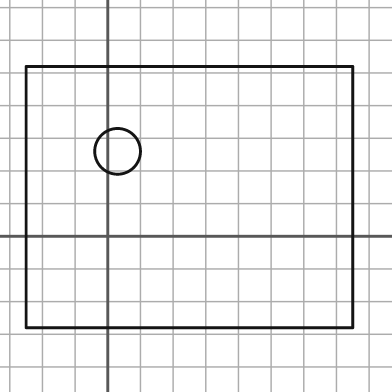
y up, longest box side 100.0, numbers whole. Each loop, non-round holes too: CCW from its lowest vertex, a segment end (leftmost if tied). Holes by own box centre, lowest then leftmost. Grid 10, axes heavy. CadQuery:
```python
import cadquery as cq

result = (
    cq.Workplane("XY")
    .moveTo(-25.0, -28.0)
    .lineTo(75.0, -28.0)
    .lineTo(75.0, 52.0)
    .lineTo(-25.0, 52.0)
    .close()
    .moveTo(3.0, 26.0)
    .circle(7.0)
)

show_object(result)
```